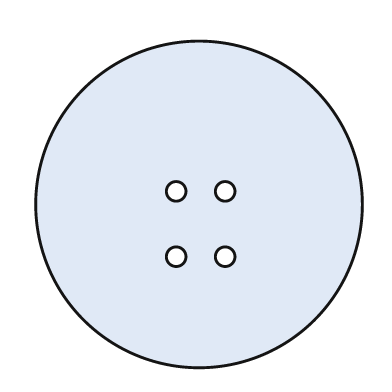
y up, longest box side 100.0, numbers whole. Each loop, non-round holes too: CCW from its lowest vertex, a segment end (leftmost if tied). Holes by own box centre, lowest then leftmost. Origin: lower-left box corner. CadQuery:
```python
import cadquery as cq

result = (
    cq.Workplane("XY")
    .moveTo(50.0, 50.0)
    .circle(50.0)
    .moveTo(43.0, 34.0)
    .circle(3.0)
    .moveTo(58.0, 34.0)
    .circle(3.0)
    .moveTo(43.0, 54.0)
    .circle(3.0)
    .moveTo(58.0, 54.0)
    .circle(3.0)
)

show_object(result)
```